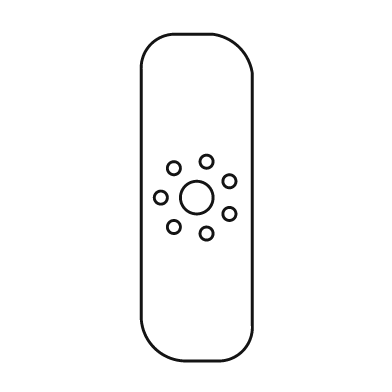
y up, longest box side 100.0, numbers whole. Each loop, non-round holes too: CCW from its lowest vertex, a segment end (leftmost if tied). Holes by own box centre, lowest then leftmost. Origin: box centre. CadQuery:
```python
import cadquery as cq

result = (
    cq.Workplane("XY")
    .moveTo(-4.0, -50.0)
    .lineTo(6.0, -50.0)
    .threePointArc((14.0, -47.0), (17.0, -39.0))
    .lineTo(17.0, 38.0)
    .threePointArc((13.0, 46.0), (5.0, 50.0))
    .lineTo(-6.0, 50.0)
    .threePointArc((-14.0, 47.0), (-17.0, 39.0))
    .lineTo(-17.0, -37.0)
    .threePointArc((-13.0, -46.0), (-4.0, -50.0))
    .close()
    .moveTo(3.0, -11.0)
    .circle(2.0)
    .moveTo(-7.0, -9.0)
    .circle(2.0)
    .moveTo(10.0, -5.0)
    .circle(2.0)
    .moveTo(-11.0, 0.0)
    .circle(2.0)
    .moveTo(0.0, 0.0)
    .circle(5.0)
    .moveTo(10.0, 5.0)
    .circle(2.0)
    .moveTo(-7.0, 9.0)
    .circle(2.0)
    .moveTo(3.0, 11.0)
    .circle(2.0)
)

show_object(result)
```